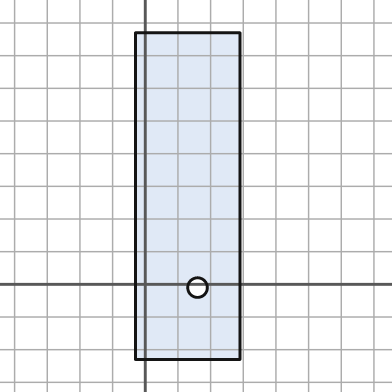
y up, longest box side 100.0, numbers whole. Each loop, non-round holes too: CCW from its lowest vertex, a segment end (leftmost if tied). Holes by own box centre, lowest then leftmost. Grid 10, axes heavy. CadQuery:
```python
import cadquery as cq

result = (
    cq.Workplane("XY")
    .moveTo(-3.0, -23.0)
    .lineTo(29.0, -23.0)
    .lineTo(29.0, 77.0)
    .lineTo(-3.0, 77.0)
    .close()
    .moveTo(16.0, -1.0)
    .circle(3.0)
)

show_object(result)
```